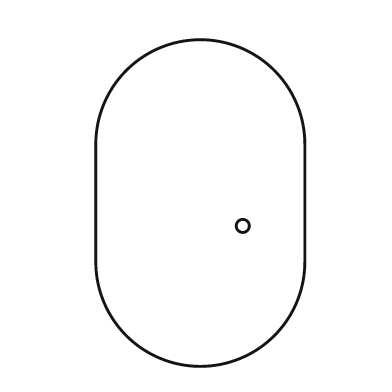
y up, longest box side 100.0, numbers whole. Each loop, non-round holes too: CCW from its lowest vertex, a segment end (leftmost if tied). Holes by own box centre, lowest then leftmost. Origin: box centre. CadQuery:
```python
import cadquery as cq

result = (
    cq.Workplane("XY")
    .moveTo(-32.0, -18.0)
    .threePointArc((0.0, -50.0), (32.0, -18.0))
    .lineTo(32.0, 18.0)
    .threePointArc((0.0, 50.0), (-32.0, 18.0))
    .close()
    .moveTo(13.0, -7.0)
    .circle(2.0)
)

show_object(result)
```